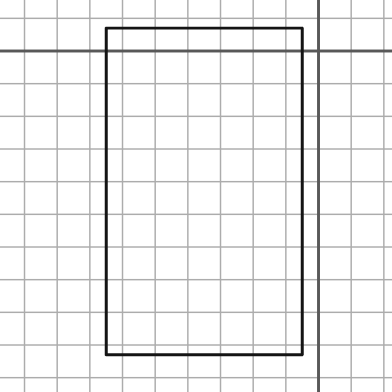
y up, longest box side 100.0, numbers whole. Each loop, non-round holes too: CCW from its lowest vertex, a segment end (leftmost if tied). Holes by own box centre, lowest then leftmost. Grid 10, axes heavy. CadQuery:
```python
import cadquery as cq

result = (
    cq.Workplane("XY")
    .moveTo(-65.0, -93.0)
    .lineTo(-5.0, -93.0)
    .lineTo(-5.0, 7.0)
    .lineTo(-65.0, 7.0)
    .close()
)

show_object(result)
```